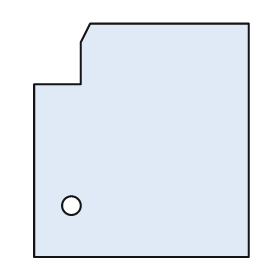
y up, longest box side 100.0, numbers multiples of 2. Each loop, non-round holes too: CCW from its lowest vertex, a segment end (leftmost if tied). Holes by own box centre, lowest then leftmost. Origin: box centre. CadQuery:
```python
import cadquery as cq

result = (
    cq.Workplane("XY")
    .moveTo(-46.0, -50.0)
    .lineTo(46.0, -50.0)
    .lineTo(46.0, 50.0)
    .lineTo(-22.0, 50.0)
    .lineTo(-26.0, 42.0)
    .lineTo(-26.0, 24.0)
    .lineTo(-46.0, 24.0)
    .close()
    .moveTo(-30.0, -28.0)
    .circle(4.0)
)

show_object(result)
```